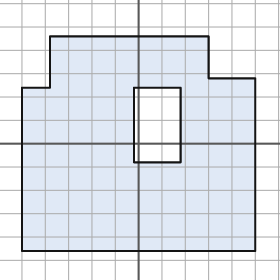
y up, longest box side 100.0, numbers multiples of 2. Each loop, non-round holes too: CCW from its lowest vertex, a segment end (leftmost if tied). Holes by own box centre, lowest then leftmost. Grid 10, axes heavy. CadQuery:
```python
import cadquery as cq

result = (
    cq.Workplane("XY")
    .moveTo(-50.0, -46.0)
    .lineTo(50.0, -46.0)
    .lineTo(50.0, 28.0)
    .lineTo(30.0, 28.0)
    .lineTo(30.0, 46.0)
    .lineTo(-38.0, 46.0)
    .lineTo(-38.0, 24.0)
    .lineTo(-50.0, 24.0)
    .close()
    .moveTo(-2.0, -8.0)
    .lineTo(18.0, -8.0)
    .lineTo(18.0, 24.0)
    .lineTo(-2.0, 24.0)
    .close()
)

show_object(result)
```